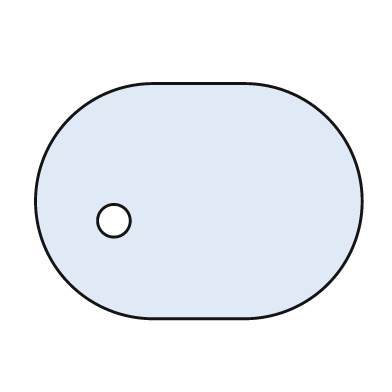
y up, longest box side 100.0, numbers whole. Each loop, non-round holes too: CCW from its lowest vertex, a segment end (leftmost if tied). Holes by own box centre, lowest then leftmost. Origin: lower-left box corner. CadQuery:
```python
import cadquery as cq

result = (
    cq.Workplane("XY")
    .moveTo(36.0, 0.0)
    .lineTo(64.0, 0.0)
    .threePointArc((100.0, 36.0), (64.0, 72.0))
    .lineTo(36.0, 72.0)
    .threePointArc((0.0, 36.0), (36.0, 0.0))
    .close()
    .moveTo(24.0, 30.0)
    .circle(5.0)
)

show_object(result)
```